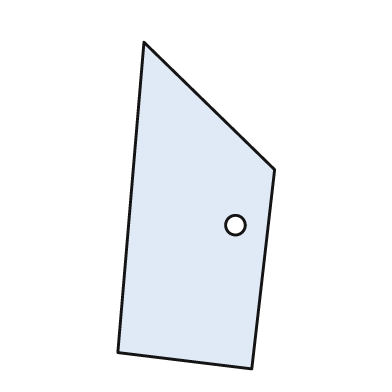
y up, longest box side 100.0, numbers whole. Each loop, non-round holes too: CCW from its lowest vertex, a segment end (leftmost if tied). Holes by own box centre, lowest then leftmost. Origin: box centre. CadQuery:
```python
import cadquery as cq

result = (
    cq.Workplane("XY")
    .moveTo(17.0, -50.0)
    .lineTo(24.0, 11.0)
    .lineTo(-16.0, 50.0)
    .lineTo(-24.0, -45.0)
    .close()
    .moveTo(12.0, -6.0)
    .circle(3.0)
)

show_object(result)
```